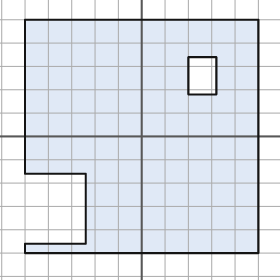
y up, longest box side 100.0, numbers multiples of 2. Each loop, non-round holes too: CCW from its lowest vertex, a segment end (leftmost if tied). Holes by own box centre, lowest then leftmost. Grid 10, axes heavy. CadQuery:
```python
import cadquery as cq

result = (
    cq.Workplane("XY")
    .moveTo(-50.0, -50.0)
    .lineTo(50.0, -50.0)
    .lineTo(50.0, 50.0)
    .lineTo(-50.0, 50.0)
    .lineTo(-50.0, -16.0)
    .lineTo(-24.0, -16.0)
    .lineTo(-24.0, -46.0)
    .lineTo(-50.0, -46.0)
    .close()
    .moveTo(20.0, 18.0)
    .lineTo(32.0, 18.0)
    .lineTo(32.0, 34.0)
    .lineTo(20.0, 34.0)
    .close()
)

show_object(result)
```